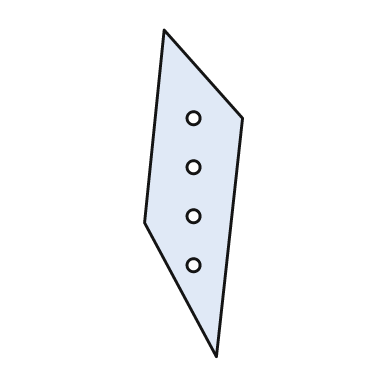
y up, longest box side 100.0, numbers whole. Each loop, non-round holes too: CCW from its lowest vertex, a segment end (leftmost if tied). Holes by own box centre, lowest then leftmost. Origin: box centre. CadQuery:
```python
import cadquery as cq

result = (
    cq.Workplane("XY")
    .moveTo(7.0, -50.0)
    .lineTo(15.0, 23.0)
    .lineTo(-9.0, 50.0)
    .lineTo(-15.0, -9.0)
    .close()
    .moveTo(0.0, -22.0)
    .circle(2.0)
    .moveTo(0.0, -7.0)
    .circle(2.0)
    .moveTo(0.0, 8.0)
    .circle(2.0)
    .moveTo(0.0, 23.0)
    .circle(2.0)
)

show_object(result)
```